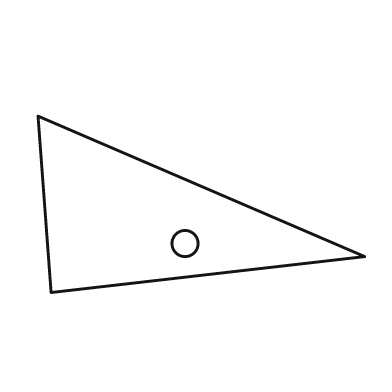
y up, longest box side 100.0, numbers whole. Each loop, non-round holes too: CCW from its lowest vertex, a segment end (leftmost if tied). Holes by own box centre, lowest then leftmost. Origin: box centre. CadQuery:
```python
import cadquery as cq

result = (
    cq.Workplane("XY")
    .moveTo(-46.0, -27.0)
    .lineTo(50.0, -16.0)
    .lineTo(-50.0, 27.0)
    .close()
    .moveTo(-5.0, -12.0)
    .circle(4.0)
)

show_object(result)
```